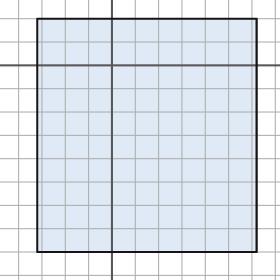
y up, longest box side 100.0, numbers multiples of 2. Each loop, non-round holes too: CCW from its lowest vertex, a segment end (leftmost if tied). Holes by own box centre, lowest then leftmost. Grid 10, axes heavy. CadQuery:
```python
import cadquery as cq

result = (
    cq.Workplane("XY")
    .moveTo(-32.0, -80.0)
    .lineTo(62.0, -80.0)
    .lineTo(62.0, 20.0)
    .lineTo(-32.0, 20.0)
    .close()
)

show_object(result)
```